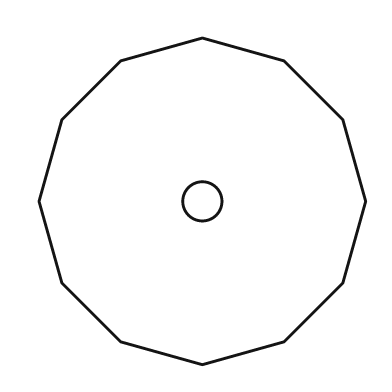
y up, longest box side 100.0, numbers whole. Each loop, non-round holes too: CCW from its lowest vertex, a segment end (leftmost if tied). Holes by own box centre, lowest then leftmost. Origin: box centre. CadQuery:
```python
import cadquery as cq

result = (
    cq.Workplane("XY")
    .moveTo(0.0, -50.0)
    .lineTo(25.0, -43.0)
    .lineTo(43.0, -25.0)
    .lineTo(50.0, 0.0)
    .lineTo(43.0, 25.0)
    .lineTo(25.0, 43.0)
    .lineTo(0.0, 50.0)
    .lineTo(-25.0, 43.0)
    .lineTo(-43.0, 25.0)
    .lineTo(-50.0, 0.0)
    .lineTo(-43.0, -25.0)
    .lineTo(-25.0, -43.0)
    .close()
    .moveTo(0.0, 0.0)
    .circle(6.0)
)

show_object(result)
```